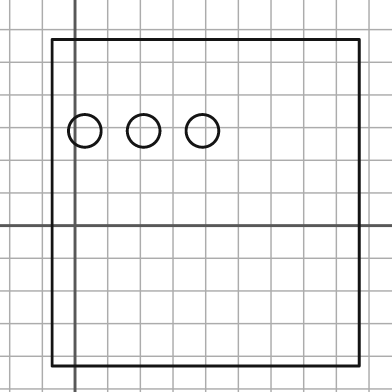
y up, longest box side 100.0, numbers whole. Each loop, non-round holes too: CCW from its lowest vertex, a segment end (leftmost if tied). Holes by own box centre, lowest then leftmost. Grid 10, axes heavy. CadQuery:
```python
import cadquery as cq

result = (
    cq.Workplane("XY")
    .moveTo(-7.0, -43.0)
    .lineTo(87.0, -43.0)
    .lineTo(87.0, 57.0)
    .lineTo(-7.0, 57.0)
    .close()
    .moveTo(3.0, 29.0)
    .circle(5.0)
    .moveTo(21.0, 29.0)
    .circle(5.0)
    .moveTo(39.0, 29.0)
    .circle(5.0)
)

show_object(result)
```